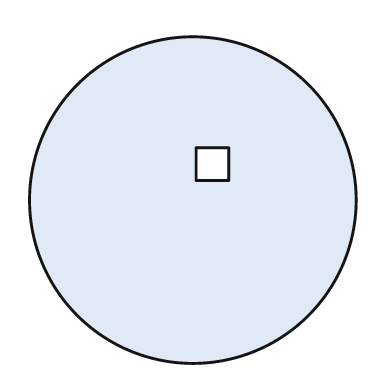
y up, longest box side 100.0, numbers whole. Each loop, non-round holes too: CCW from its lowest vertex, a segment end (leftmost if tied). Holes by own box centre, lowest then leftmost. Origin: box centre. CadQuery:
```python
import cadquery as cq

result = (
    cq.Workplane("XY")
    .moveTo(0.0, 0.0)
    .circle(50.0)
    .moveTo(1.0, 6.0)
    .lineTo(11.0, 6.0)
    .lineTo(11.0, 16.0)
    .lineTo(1.0, 16.0)
    .close()
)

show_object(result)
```